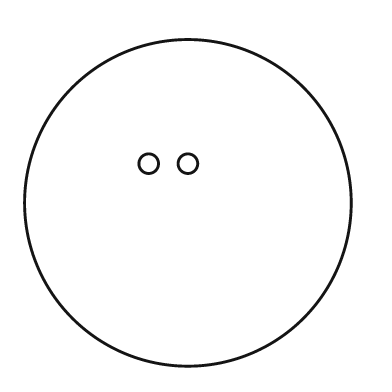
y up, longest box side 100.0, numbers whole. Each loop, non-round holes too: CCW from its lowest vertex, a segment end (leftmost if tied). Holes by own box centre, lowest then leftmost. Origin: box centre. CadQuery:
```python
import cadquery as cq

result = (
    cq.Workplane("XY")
    .moveTo(0.0, 0.0)
    .circle(50.0)
    .moveTo(-12.0, 12.0)
    .circle(3.0)
    .moveTo(0.0, 12.0)
    .circle(3.0)
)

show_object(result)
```